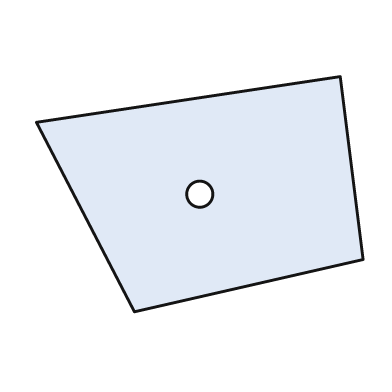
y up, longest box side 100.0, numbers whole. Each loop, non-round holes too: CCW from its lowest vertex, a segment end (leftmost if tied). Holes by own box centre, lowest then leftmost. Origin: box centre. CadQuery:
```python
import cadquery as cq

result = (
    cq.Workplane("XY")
    .moveTo(-20.0, -36.0)
    .lineTo(50.0, -20.0)
    .lineTo(43.0, 36.0)
    .lineTo(-50.0, 22.0)
    .close()
    .moveTo(0.0, 0.0)
    .circle(4.0)
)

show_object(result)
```